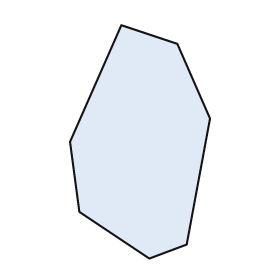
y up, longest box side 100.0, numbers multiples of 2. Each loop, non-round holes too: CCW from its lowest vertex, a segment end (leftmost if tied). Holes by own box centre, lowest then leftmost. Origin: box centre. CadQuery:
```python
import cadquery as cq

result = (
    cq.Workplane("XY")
    .moveTo(4.0, -50.0)
    .lineTo(20.0, -44.0)
    .lineTo(30.0, 10.0)
    .lineTo(16.0, 42.0)
    .lineTo(-8.0, 50.0)
    .lineTo(-30.0, 0.0)
    .lineTo(-26.0, -30.0)
    .close()
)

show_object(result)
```